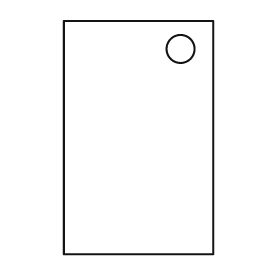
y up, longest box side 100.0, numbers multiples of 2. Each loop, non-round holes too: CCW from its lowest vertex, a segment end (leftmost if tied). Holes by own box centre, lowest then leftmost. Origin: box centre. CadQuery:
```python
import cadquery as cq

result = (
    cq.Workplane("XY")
    .moveTo(-32.0, -50.0)
    .lineTo(32.0, -50.0)
    .lineTo(32.0, 50.0)
    .lineTo(-32.0, 50.0)
    .close()
    .moveTo(18.0, 38.0)
    .circle(6.0)
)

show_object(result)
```